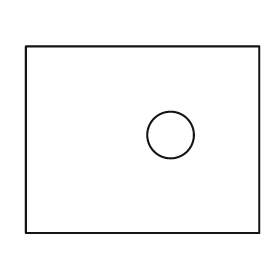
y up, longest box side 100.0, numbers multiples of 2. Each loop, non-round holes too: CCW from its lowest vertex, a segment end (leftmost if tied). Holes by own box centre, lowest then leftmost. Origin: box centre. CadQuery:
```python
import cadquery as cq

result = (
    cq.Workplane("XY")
    .moveTo(-50.0, -40.0)
    .lineTo(50.0, -40.0)
    .lineTo(50.0, 40.0)
    .lineTo(-50.0, 40.0)
    .close()
    .moveTo(12.0, 2.0)
    .circle(10.0)
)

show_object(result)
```